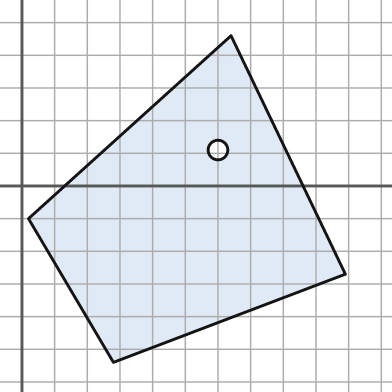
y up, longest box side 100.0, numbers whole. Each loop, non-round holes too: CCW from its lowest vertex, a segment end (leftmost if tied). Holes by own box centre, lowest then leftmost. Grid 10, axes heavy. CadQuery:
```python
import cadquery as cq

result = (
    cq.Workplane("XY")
    .moveTo(28.0, -54.0)
    .lineTo(99.0, -27.0)
    .lineTo(64.0, 46.0)
    .lineTo(2.0, -10.0)
    .close()
    .moveTo(60.0, 11.0)
    .circle(3.0)
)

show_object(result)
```